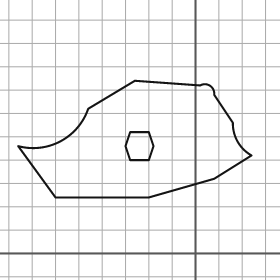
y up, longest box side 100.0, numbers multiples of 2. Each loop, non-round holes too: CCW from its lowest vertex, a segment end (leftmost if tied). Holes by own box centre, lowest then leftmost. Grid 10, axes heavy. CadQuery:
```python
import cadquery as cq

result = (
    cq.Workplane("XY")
    .moveTo(-60.0, 24.0)
    .lineTo(-20.0, 24.0)
    .lineTo(8.0, 32.0)
    .lineTo(24.0, 42.0)
    .threePointArc((18.0, 48.0), (16.0, 56.0))
    .lineTo(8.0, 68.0)
    .threePointArc((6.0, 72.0), (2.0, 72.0))
    .lineTo(-26.0, 74.0)
    .lineTo(-46.0, 62.0)
    .threePointArc((-58.0, 48.0), (-76.0, 46.0))
    .close()
    .moveTo(-28.0, 40.0)
    .lineTo(-20.0, 40.0)
    .lineTo(-18.0, 46.0)
    .lineTo(-20.0, 52.0)
    .lineTo(-28.0, 52.0)
    .lineTo(-30.0, 46.0)
    .close()
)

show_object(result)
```